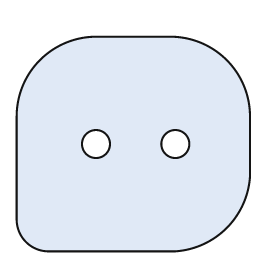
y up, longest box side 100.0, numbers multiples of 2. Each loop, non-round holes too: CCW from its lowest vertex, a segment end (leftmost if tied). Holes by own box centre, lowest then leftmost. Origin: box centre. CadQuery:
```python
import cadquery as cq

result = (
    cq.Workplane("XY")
    .moveTo(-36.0, -46.0)
    .lineTo(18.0, -46.0)
    .threePointArc((40.0, -36.0), (50.0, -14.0))
    .lineTo(50.0, 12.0)
    .threePointArc((40.0, 36.0), (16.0, 46.0))
    .lineTo(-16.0, 46.0)
    .threePointArc((-40.0, 36.0), (-50.0, 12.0))
    .lineTo(-50.0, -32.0)
    .threePointArc((-46.0, -42.0), (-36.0, -46.0))
    .close()
    .moveTo(-16.0, 0.0)
    .circle(6.0)
    .moveTo(18.0, 0.0)
    .circle(6.0)
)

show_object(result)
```